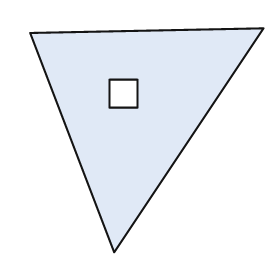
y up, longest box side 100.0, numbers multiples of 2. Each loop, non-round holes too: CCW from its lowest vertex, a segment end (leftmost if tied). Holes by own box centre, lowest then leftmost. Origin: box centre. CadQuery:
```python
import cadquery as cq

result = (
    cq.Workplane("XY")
    .moveTo(-14.0, -48.0)
    .lineTo(50.0, 48.0)
    .lineTo(-50.0, 46.0)
    .close()
    .moveTo(-16.0, 14.0)
    .lineTo(-4.0, 14.0)
    .lineTo(-4.0, 26.0)
    .lineTo(-16.0, 26.0)
    .close()
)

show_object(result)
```